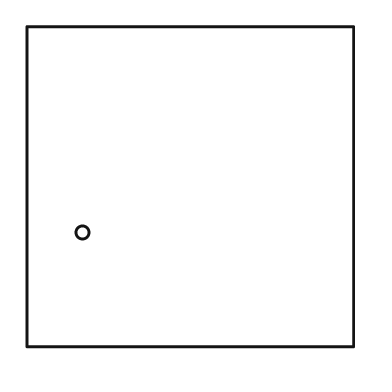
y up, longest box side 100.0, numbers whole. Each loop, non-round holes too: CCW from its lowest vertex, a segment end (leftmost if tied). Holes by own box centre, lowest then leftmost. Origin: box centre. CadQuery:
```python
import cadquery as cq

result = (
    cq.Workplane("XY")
    .moveTo(-50.0, -49.0)
    .lineTo(50.0, -49.0)
    .lineTo(50.0, 49.0)
    .lineTo(-50.0, 49.0)
    .close()
    .moveTo(-33.0, -14.0)
    .circle(2.0)
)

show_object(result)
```